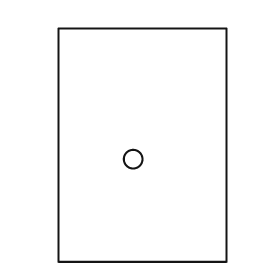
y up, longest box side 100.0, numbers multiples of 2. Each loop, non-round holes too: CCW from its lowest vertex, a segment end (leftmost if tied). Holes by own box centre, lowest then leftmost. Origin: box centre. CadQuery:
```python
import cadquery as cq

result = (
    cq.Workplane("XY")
    .moveTo(-36.0, -50.0)
    .lineTo(36.0, -50.0)
    .lineTo(36.0, 50.0)
    .lineTo(-36.0, 50.0)
    .close()
    .moveTo(-4.0, -6.0)
    .circle(4.0)
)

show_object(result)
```